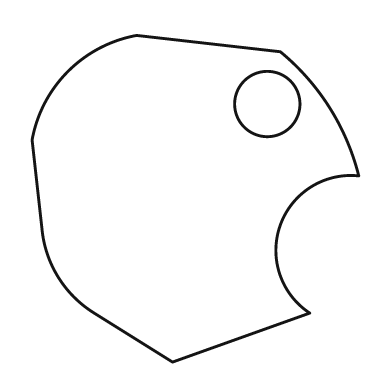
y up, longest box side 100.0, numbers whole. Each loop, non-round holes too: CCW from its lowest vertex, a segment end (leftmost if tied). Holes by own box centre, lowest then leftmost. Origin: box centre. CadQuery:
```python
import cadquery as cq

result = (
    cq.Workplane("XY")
    .moveTo(-7.0, -50.0)
    .lineTo(35.0, -35.0)
    .threePointArc((26.0, -8.0), (50.0, 7.0))
    .threePointArc((41.0, 28.0), (26.0, 45.0))
    .lineTo(-18.0, 50.0)
    .threePointArc((-39.0, 39.0), (-50.0, 18.0))
    .lineTo(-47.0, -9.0)
    .threePointArc((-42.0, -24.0), (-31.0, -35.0))
    .close()
    .moveTo(22.0, 29.0)
    .circle(10.0)
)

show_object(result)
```